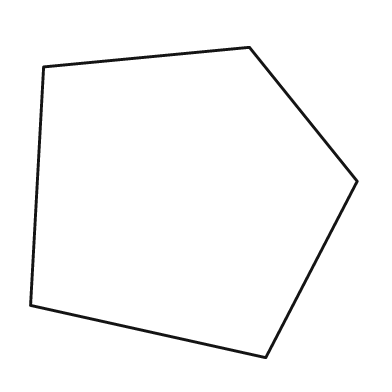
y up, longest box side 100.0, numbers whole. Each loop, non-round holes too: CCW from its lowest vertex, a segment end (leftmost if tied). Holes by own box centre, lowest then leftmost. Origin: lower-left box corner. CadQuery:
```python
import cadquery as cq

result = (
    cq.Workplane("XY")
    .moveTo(72.0, 0.0)
    .lineTo(100.0, 54.0)
    .lineTo(67.0, 95.0)
    .lineTo(4.0, 89.0)
    .lineTo(0.0, 16.0)
    .close()
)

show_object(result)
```